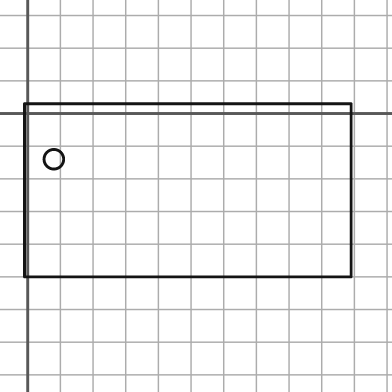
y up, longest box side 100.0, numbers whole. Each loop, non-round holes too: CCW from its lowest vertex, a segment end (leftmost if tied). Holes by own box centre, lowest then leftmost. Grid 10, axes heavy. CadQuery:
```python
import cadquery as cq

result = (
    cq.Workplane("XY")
    .moveTo(-1.0, -50.0)
    .lineTo(99.0, -50.0)
    .lineTo(99.0, 3.0)
    .lineTo(-1.0, 3.0)
    .close()
    .moveTo(8.0, -14.0)
    .circle(3.0)
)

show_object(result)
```